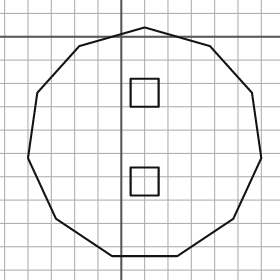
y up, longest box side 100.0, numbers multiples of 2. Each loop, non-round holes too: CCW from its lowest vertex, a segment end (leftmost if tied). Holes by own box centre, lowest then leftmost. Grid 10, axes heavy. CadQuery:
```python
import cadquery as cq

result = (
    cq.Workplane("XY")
    .moveTo(-4.0, -94.0)
    .lineTo(24.0, -94.0)
    .lineTo(48.0, -78.0)
    .lineTo(60.0, -52.0)
    .lineTo(56.0, -24.0)
    .lineTo(38.0, -4.0)
    .lineTo(10.0, 4.0)
    .lineTo(-18.0, -4.0)
    .lineTo(-36.0, -24.0)
    .lineTo(-40.0, -52.0)
    .lineTo(-28.0, -78.0)
    .close()
    .moveTo(4.0, -68.0)
    .lineTo(16.0, -68.0)
    .lineTo(16.0, -56.0)
    .lineTo(4.0, -56.0)
    .close()
    .moveTo(4.0, -30.0)
    .lineTo(16.0, -30.0)
    .lineTo(16.0, -18.0)
    .lineTo(4.0, -18.0)
    .close()
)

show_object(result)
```